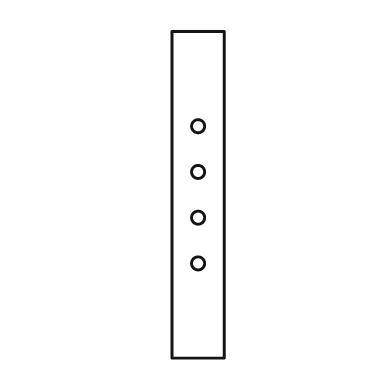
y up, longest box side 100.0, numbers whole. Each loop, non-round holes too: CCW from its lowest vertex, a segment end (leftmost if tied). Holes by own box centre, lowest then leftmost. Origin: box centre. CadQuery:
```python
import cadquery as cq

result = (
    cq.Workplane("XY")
    .moveTo(-8.0, -50.0)
    .lineTo(8.0, -50.0)
    .lineTo(8.0, 50.0)
    .lineTo(-8.0, 50.0)
    .close()
    .moveTo(0.0, -21.0)
    .circle(2.0)
    .moveTo(0.0, -7.0)
    .circle(2.0)
    .moveTo(0.0, 7.0)
    .circle(2.0)
    .moveTo(0.0, 21.0)
    .circle(2.0)
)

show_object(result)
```